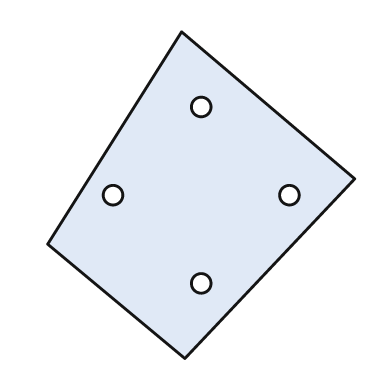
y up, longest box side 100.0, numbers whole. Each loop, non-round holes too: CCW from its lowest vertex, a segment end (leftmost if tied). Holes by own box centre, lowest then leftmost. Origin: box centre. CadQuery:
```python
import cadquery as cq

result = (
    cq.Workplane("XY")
    .moveTo(-5.0, -50.0)
    .lineTo(47.0, 5.0)
    .lineTo(-6.0, 50.0)
    .lineTo(-47.0, -15.0)
    .close()
    .moveTo(0.0, -27.0)
    .circle(3.0)
    .moveTo(-27.0, 0.0)
    .circle(3.0)
    .moveTo(27.0, 0.0)
    .circle(3.0)
    .moveTo(0.0, 27.0)
    .circle(3.0)
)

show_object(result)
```